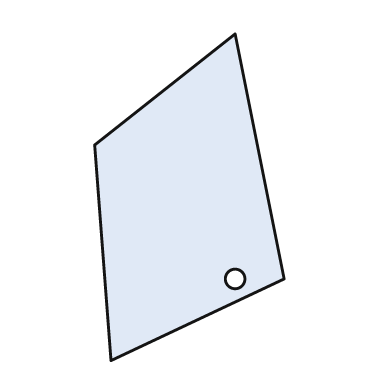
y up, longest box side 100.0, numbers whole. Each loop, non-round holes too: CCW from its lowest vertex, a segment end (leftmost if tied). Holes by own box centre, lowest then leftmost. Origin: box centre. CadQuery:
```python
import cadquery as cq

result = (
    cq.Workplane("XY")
    .moveTo(-24.0, -50.0)
    .lineTo(29.0, -25.0)
    .lineTo(14.0, 50.0)
    .lineTo(-29.0, 16.0)
    .close()
    .moveTo(14.0, -25.0)
    .circle(3.0)
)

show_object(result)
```